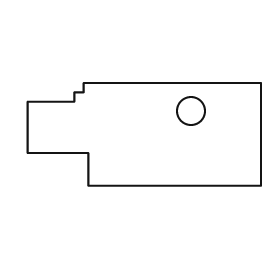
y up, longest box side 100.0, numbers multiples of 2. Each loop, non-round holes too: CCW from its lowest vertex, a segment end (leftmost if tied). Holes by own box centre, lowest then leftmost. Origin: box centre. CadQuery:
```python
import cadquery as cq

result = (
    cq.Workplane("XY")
    .moveTo(-24.0, -22.0)
    .lineTo(50.0, -22.0)
    .lineTo(50.0, 22.0)
    .lineTo(-26.0, 22.0)
    .lineTo(-26.0, 18.0)
    .lineTo(-30.0, 18.0)
    .lineTo(-30.0, 14.0)
    .lineTo(-50.0, 14.0)
    .lineTo(-50.0, -8.0)
    .lineTo(-24.0, -8.0)
    .close()
    .moveTo(20.0, 10.0)
    .circle(6.0)
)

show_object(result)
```